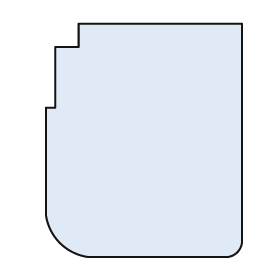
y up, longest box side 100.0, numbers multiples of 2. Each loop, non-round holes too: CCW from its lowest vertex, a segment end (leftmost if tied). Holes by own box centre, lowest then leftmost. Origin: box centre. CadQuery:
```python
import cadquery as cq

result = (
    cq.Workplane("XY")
    .moveTo(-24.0, -50.0)
    .lineTo(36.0, -50.0)
    .threePointArc((40.0, -48.0), (42.0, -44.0))
    .lineTo(42.0, 50.0)
    .lineTo(-28.0, 50.0)
    .lineTo(-28.0, 40.0)
    .lineTo(-38.0, 40.0)
    .lineTo(-38.0, 14.0)
    .lineTo(-42.0, 14.0)
    .lineTo(-42.0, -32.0)
    .threePointArc((-36.0, -44.0), (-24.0, -50.0))
    .close()
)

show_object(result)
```